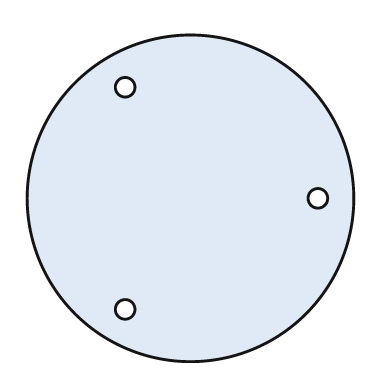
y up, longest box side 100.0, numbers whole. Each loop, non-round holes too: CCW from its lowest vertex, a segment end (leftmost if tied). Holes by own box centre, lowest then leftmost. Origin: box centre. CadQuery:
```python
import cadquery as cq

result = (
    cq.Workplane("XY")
    .moveTo(0.0, 0.0)
    .circle(50.0)
    .moveTo(-20.0, -34.0)
    .circle(3.0)
    .moveTo(39.0, 0.0)
    .circle(3.0)
    .moveTo(-20.0, 34.0)
    .circle(3.0)
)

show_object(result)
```